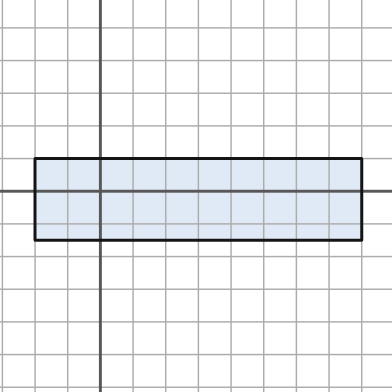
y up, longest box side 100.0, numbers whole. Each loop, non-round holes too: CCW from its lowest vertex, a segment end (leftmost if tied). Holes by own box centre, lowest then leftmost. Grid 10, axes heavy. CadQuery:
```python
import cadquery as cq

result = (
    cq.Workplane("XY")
    .moveTo(-20.0, -15.0)
    .lineTo(80.0, -15.0)
    .lineTo(80.0, 10.0)
    .lineTo(-20.0, 10.0)
    .close()
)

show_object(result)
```